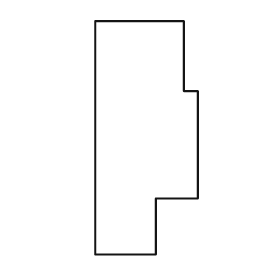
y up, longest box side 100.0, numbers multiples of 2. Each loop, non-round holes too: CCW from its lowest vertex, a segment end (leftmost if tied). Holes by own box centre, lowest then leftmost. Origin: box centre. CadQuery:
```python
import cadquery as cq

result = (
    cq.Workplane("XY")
    .moveTo(-22.0, -50.0)
    .lineTo(4.0, -50.0)
    .lineTo(4.0, -26.0)
    .lineTo(22.0, -26.0)
    .lineTo(22.0, 20.0)
    .lineTo(16.0, 20.0)
    .lineTo(16.0, 50.0)
    .lineTo(-22.0, 50.0)
    .close()
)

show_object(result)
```